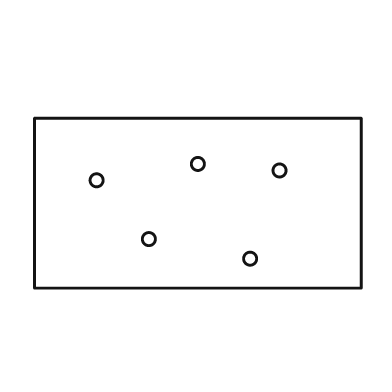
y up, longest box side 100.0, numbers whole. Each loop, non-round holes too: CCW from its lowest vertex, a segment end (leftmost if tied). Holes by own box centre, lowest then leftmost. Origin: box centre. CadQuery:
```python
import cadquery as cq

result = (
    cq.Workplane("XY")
    .moveTo(-50.0, -26.0)
    .lineTo(50.0, -26.0)
    .lineTo(50.0, 26.0)
    .lineTo(-50.0, 26.0)
    .close()
    .moveTo(16.0, -17.0)
    .circle(2.0)
    .moveTo(-15.0, -11.0)
    .circle(2.0)
    .moveTo(-31.0, 7.0)
    .circle(2.0)
    .moveTo(25.0, 10.0)
    .circle(2.0)
    .moveTo(0.0, 12.0)
    .circle(2.0)
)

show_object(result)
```